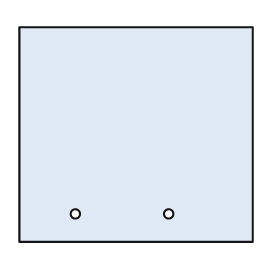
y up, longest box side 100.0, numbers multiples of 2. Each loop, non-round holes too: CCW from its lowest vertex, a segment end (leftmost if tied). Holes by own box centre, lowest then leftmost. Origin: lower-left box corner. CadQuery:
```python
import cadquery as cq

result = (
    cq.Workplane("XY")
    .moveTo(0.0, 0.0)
    .lineTo(100.0, 0.0)
    .lineTo(100.0, 92.0)
    .lineTo(0.0, 92.0)
    .close()
    .moveTo(24.0, 12.0)
    .circle(2.0)
    .moveTo(64.0, 12.0)
    .circle(2.0)
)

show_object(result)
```